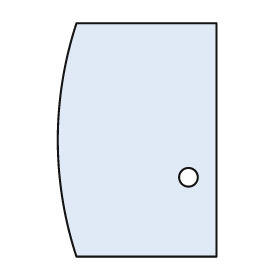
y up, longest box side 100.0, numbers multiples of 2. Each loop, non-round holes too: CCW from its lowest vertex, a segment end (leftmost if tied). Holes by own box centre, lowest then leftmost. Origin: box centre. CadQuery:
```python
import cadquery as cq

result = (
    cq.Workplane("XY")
    .moveTo(-26.0, -50.0)
    .lineTo(34.0, -50.0)
    .lineTo(34.0, 50.0)
    .lineTo(-26.0, 50.0)
    .threePointArc((-34.0, 0.0), (-26.0, -50.0))
    .close()
    .moveTo(22.0, -16.0)
    .circle(4.0)
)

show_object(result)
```